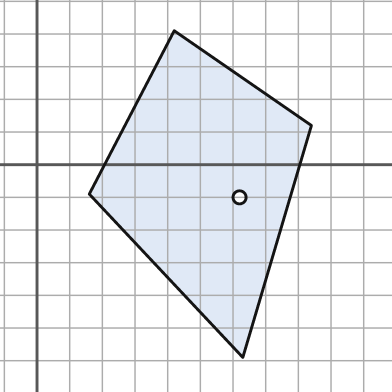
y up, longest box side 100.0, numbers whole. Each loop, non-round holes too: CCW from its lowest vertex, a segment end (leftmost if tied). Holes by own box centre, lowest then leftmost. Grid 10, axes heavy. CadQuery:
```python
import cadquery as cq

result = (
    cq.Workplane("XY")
    .moveTo(63.0, -59.0)
    .lineTo(84.0, 12.0)
    .lineTo(42.0, 41.0)
    .lineTo(16.0, -9.0)
    .close()
    .moveTo(62.0, -10.0)
    .circle(2.0)
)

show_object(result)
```